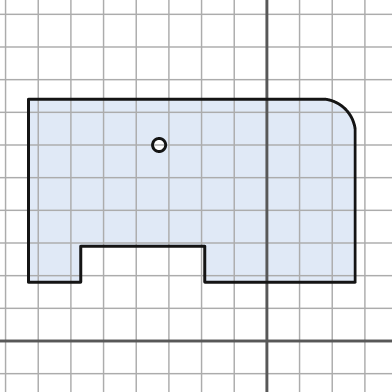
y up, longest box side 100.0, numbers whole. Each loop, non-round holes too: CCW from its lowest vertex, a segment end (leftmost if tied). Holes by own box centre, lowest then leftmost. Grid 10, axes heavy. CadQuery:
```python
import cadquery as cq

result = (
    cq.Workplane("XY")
    .moveTo(-73.0, 18.0)
    .lineTo(-57.0, 18.0)
    .lineTo(-57.0, 29.0)
    .lineTo(-19.0, 29.0)
    .lineTo(-19.0, 18.0)
    .lineTo(27.0, 18.0)
    .lineTo(27.0, 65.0)
    .threePointArc((24.0, 71.0), (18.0, 74.0))
    .lineTo(-73.0, 74.0)
    .close()
    .moveTo(-33.0, 60.0)
    .circle(2.0)
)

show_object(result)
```